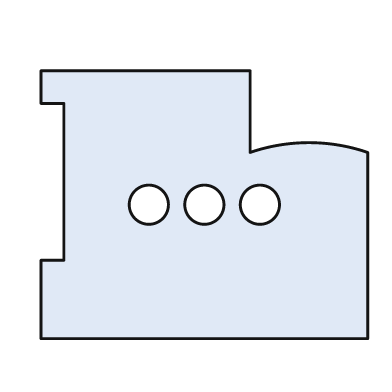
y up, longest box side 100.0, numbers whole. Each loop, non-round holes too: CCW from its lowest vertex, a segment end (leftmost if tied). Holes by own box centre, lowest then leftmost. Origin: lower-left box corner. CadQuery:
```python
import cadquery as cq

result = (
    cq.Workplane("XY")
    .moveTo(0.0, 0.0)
    .lineTo(100.0, 0.0)
    .lineTo(100.0, 57.0)
    .threePointArc((82.0, 60.0), (64.0, 57.0))
    .lineTo(64.0, 82.0)
    .lineTo(0.0, 82.0)
    .lineTo(0.0, 72.0)
    .lineTo(7.0, 72.0)
    .lineTo(7.0, 24.0)
    .lineTo(0.0, 24.0)
    .close()
    .moveTo(33.0, 41.0)
    .circle(6.0)
    .moveTo(50.0, 41.0)
    .circle(6.0)
    .moveTo(67.0, 41.0)
    .circle(6.0)
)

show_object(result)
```